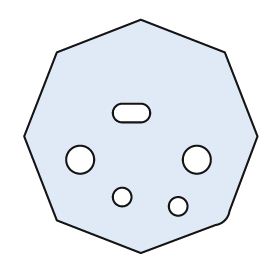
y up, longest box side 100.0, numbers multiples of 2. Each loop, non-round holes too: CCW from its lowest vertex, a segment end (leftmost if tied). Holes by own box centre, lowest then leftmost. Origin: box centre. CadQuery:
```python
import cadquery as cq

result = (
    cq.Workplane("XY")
    .moveTo(0.0, -50.0)
    .lineTo(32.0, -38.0)
    .threePointArc((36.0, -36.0), (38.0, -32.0))
    .lineTo(50.0, 0.0)
    .lineTo(36.0, 36.0)
    .lineTo(0.0, 50.0)
    .lineTo(-36.0, 36.0)
    .lineTo(-50.0, 0.0)
    .lineTo(-36.0, -36.0)
    .close()
    .moveTo(16.0, -30.0)
    .circle(4.0)
    .moveTo(-8.0, -26.0)
    .circle(4.0)
    .moveTo(-26.0, -10.0)
    .circle(6.0)
    .moveTo(24.0, -10.0)
    .circle(6.0)
    .moveTo(-8.0, 6.0)
    .lineTo(0.0, 6.0)
    .threePointArc((4.0, 10.0), (0.0, 14.0))
    .lineTo(-8.0, 14.0)
    .threePointArc((-12.0, 10.0), (-8.0, 6.0))
    .close()
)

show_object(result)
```